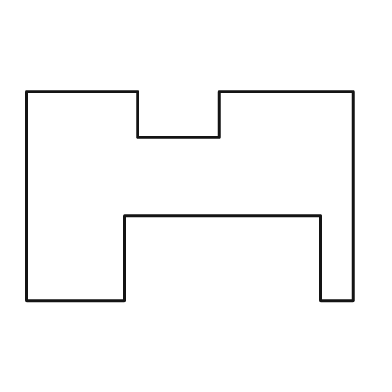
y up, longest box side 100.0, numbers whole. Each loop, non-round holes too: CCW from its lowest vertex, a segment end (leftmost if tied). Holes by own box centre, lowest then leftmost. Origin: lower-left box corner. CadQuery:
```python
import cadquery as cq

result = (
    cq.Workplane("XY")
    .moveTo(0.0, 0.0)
    .lineTo(30.0, 0.0)
    .lineTo(30.0, 26.0)
    .lineTo(90.0, 26.0)
    .lineTo(90.0, 0.0)
    .lineTo(100.0, 0.0)
    .lineTo(100.0, 64.0)
    .lineTo(59.0, 64.0)
    .lineTo(59.0, 50.0)
    .lineTo(34.0, 50.0)
    .lineTo(34.0, 64.0)
    .lineTo(0.0, 64.0)
    .close()
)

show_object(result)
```